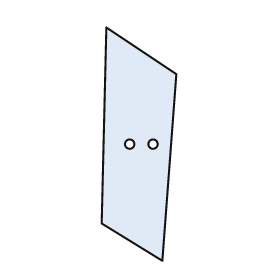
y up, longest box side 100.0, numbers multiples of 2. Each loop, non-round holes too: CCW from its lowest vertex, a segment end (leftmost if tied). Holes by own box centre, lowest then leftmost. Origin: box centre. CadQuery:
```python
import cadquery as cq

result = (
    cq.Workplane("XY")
    .moveTo(10.0, -50.0)
    .lineTo(16.0, 30.0)
    .lineTo(-14.0, 50.0)
    .lineTo(-16.0, -34.0)
    .close()
    .moveTo(-4.0, 0.0)
    .circle(2.0)
    .moveTo(6.0, 0.0)
    .circle(2.0)
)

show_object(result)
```